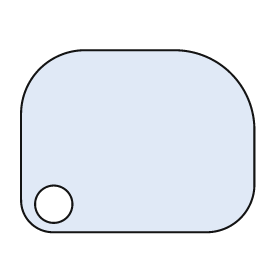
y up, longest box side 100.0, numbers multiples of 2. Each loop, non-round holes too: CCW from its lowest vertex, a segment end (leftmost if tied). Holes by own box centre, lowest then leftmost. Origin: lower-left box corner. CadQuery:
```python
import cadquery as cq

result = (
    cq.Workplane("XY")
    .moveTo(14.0, 0.0)
    .lineTo(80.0, 0.0)
    .threePointArc((94.0, 6.0), (100.0, 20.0))
    .lineTo(100.0, 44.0)
    .threePointArc((90.0, 68.0), (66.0, 78.0))
    .lineTo(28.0, 78.0)
    .threePointArc((8.0, 70.0), (0.0, 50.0))
    .lineTo(0.0, 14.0)
    .threePointArc((4.0, 4.0), (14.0, 0.0))
    .close()
    .moveTo(14.0, 12.0)
    .circle(8.0)
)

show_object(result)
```